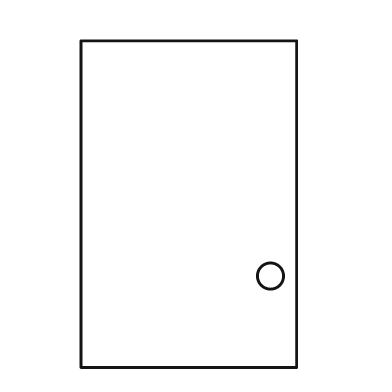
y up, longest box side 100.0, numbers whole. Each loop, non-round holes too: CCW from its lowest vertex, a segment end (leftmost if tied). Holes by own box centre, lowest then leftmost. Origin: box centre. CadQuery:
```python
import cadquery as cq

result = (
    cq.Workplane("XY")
    .moveTo(-33.0, -50.0)
    .lineTo(33.0, -50.0)
    .lineTo(33.0, 50.0)
    .lineTo(-33.0, 50.0)
    .close()
    .moveTo(25.0, -22.0)
    .circle(4.0)
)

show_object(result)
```